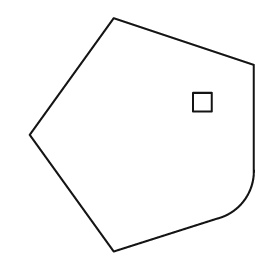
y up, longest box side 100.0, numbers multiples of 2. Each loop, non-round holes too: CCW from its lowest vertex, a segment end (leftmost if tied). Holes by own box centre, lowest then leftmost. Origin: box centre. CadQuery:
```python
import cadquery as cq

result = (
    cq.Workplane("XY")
    .moveTo(-12.0, -50.0)
    .lineTo(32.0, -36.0)
    .threePointArc((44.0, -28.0), (48.0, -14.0))
    .lineTo(48.0, 30.0)
    .lineTo(-12.0, 50.0)
    .lineTo(-48.0, 0.0)
    .close()
    .moveTo(22.0, 10.0)
    .lineTo(30.0, 10.0)
    .lineTo(30.0, 18.0)
    .lineTo(22.0, 18.0)
    .close()
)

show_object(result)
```